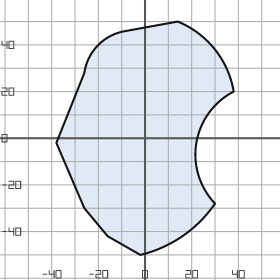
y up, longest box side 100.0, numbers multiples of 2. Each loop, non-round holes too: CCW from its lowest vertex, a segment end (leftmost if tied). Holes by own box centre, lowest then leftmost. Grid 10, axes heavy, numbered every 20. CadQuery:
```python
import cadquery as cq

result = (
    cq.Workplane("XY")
    .moveTo(-2.0, -50.0)
    .threePointArc((16.0, -42.0), (30.0, -28.0))
    .threePointArc((22.0, -2.0), (38.0, 20.0))
    .threePointArc((30.0, 38.0), (14.0, 50.0))
    .lineTo(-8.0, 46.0)
    .threePointArc((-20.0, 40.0), (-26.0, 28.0))
    .lineTo(-38.0, -2.0)
    .lineTo(-26.0, -30.0)
    .lineTo(-16.0, -42.0)
    .close()
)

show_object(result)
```